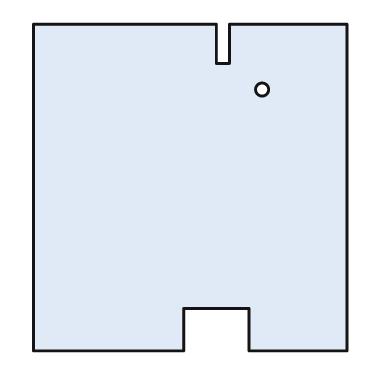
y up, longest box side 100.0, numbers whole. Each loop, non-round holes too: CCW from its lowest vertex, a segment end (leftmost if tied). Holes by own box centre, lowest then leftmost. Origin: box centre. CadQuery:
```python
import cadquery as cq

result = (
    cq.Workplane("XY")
    .moveTo(-48.0, -50.0)
    .lineTo(-2.0, -50.0)
    .lineTo(-2.0, -37.0)
    .lineTo(18.0, -37.0)
    .lineTo(18.0, -50.0)
    .lineTo(48.0, -50.0)
    .lineTo(48.0, 50.0)
    .lineTo(12.0, 50.0)
    .lineTo(12.0, 38.0)
    .lineTo(8.0, 38.0)
    .lineTo(8.0, 50.0)
    .lineTo(-48.0, 50.0)
    .close()
    .moveTo(22.0, 30.0)
    .circle(2.0)
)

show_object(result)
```